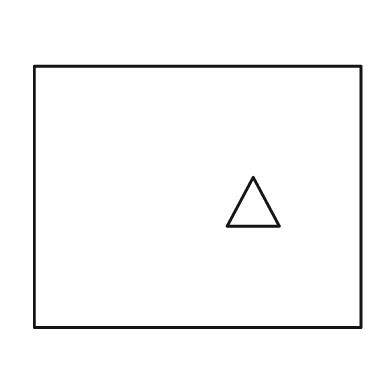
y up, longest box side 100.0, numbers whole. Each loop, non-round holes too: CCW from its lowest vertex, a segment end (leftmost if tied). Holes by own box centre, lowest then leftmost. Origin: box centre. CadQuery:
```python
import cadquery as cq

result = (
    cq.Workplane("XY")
    .moveTo(-50.0, -40.0)
    .lineTo(50.0, -40.0)
    .lineTo(50.0, 40.0)
    .lineTo(-50.0, 40.0)
    .close()
    .moveTo(9.0, -9.0)
    .lineTo(25.0, -9.0)
    .lineTo(17.0, 6.0)
    .close()
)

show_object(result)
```